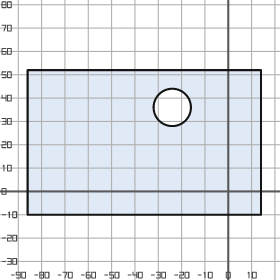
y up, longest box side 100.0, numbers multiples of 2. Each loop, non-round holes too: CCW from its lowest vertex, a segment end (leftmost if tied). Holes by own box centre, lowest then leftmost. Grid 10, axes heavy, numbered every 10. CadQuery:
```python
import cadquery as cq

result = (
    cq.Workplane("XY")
    .moveTo(-86.0, -10.0)
    .lineTo(14.0, -10.0)
    .lineTo(14.0, 52.0)
    .lineTo(-86.0, 52.0)
    .close()
    .moveTo(-24.0, 36.0)
    .circle(8.0)
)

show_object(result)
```